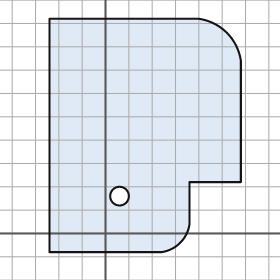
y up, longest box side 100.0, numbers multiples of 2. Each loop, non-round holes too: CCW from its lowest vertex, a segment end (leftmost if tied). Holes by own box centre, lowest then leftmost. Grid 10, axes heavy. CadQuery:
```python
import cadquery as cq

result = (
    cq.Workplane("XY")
    .moveTo(-24.0, -8.0)
    .lineTo(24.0, -8.0)
    .threePointArc((32.0, -4.0), (36.0, 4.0))
    .lineTo(36.0, 22.0)
    .lineTo(58.0, 22.0)
    .lineTo(58.0, 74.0)
    .threePointArc((52.0, 86.0), (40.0, 92.0))
    .lineTo(-24.0, 92.0)
    .close()
    .moveTo(6.0, 16.0)
    .circle(4.0)
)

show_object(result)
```